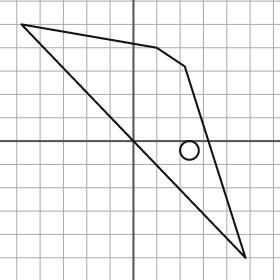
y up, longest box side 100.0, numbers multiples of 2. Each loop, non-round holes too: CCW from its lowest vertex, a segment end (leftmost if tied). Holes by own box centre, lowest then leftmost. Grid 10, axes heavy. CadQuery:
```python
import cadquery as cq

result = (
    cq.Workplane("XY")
    .moveTo(48.0, -50.0)
    .lineTo(22.0, 32.0)
    .lineTo(10.0, 40.0)
    .lineTo(-48.0, 50.0)
    .close()
    .moveTo(24.0, -4.0)
    .circle(4.0)
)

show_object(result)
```